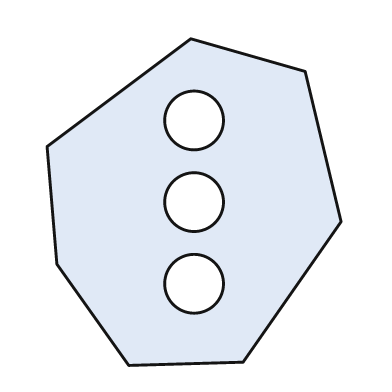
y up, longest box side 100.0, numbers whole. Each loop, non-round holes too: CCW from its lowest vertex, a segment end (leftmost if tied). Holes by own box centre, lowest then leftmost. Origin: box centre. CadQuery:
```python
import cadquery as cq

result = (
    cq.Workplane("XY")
    .moveTo(-20.0, -50.0)
    .lineTo(15.0, -49.0)
    .lineTo(45.0, -6.0)
    .lineTo(34.0, 40.0)
    .lineTo(-1.0, 50.0)
    .lineTo(-45.0, 17.0)
    .lineTo(-42.0, -19.0)
    .close()
    .moveTo(0.0, -25.0)
    .circle(9.0)
    .moveTo(0.0, 0.0)
    .circle(9.0)
    .moveTo(0.0, 25.0)
    .circle(9.0)
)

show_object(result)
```